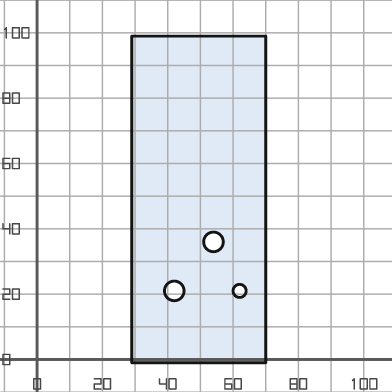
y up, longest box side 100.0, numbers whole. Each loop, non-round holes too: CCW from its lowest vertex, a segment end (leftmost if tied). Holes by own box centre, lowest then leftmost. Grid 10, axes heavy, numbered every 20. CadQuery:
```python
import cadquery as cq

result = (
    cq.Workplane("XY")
    .moveTo(29.0, -1.0)
    .lineTo(70.0, -1.0)
    .lineTo(70.0, 99.0)
    .lineTo(29.0, 99.0)
    .close()
    .moveTo(42.0, 21.0)
    .circle(3.0)
    .moveTo(62.0, 21.0)
    .circle(2.0)
    .moveTo(54.0, 36.0)
    .circle(3.0)
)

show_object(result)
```